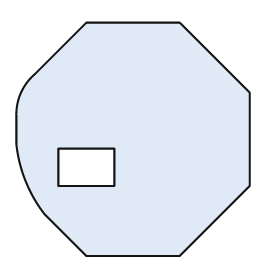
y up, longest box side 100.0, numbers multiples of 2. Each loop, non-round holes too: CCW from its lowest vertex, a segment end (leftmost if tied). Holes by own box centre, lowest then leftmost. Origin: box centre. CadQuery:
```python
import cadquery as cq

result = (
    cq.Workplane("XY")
    .moveTo(-20.0, -50.0)
    .lineTo(20.0, -50.0)
    .lineTo(50.0, -20.0)
    .lineTo(50.0, 20.0)
    .lineTo(20.0, 50.0)
    .lineTo(-20.0, 50.0)
    .lineTo(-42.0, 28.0)
    .threePointArc((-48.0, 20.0), (-50.0, 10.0))
    .lineTo(-50.0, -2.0)
    .threePointArc((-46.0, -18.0), (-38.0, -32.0))
    .close()
    .moveTo(-32.0, -20.0)
    .lineTo(-8.0, -20.0)
    .lineTo(-8.0, -4.0)
    .lineTo(-32.0, -4.0)
    .close()
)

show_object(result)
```